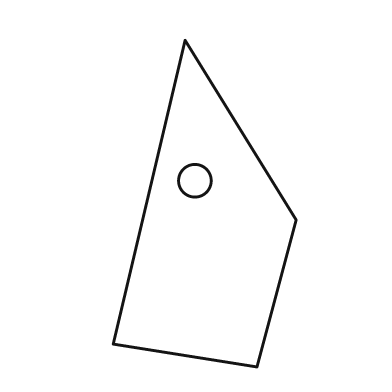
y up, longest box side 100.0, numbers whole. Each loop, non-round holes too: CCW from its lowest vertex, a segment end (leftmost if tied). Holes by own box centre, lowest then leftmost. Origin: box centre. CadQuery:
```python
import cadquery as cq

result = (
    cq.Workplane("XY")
    .moveTo(16.0, -50.0)
    .lineTo(28.0, -5.0)
    .lineTo(-6.0, 50.0)
    .lineTo(-28.0, -43.0)
    .close()
    .moveTo(-3.0, 7.0)
    .circle(5.0)
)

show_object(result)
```